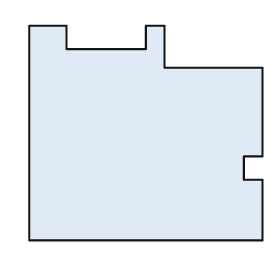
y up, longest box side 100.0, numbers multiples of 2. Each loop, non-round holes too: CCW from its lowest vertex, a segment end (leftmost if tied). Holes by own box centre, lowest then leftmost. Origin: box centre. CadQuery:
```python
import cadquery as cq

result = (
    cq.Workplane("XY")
    .moveTo(-50.0, -46.0)
    .lineTo(50.0, -46.0)
    .lineTo(50.0, -20.0)
    .lineTo(42.0, -20.0)
    .lineTo(42.0, -10.0)
    .lineTo(50.0, -10.0)
    .lineTo(50.0, 28.0)
    .lineTo(8.0, 28.0)
    .lineTo(8.0, 46.0)
    .lineTo(0.0, 46.0)
    .lineTo(0.0, 36.0)
    .lineTo(-34.0, 36.0)
    .lineTo(-34.0, 46.0)
    .lineTo(-50.0, 46.0)
    .close()
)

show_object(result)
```